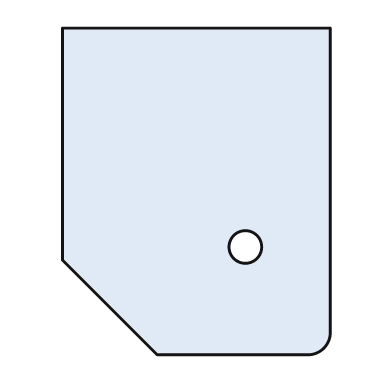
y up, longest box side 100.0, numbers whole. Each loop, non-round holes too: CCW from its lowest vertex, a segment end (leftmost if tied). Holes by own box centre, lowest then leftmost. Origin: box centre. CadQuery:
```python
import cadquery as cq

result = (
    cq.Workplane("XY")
    .moveTo(-12.0, -50.0)
    .lineTo(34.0, -50.0)
    .threePointArc((39.0, -48.0), (41.0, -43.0))
    .lineTo(41.0, 50.0)
    .lineTo(-41.0, 50.0)
    .lineTo(-41.0, -21.0)
    .close()
    .moveTo(15.0, -17.0)
    .circle(5.0)
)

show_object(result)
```